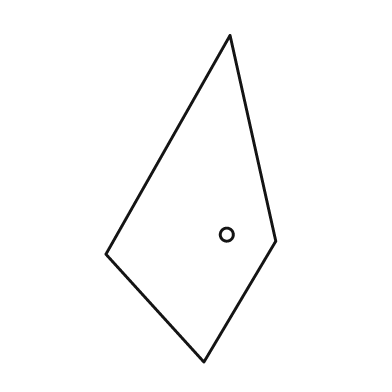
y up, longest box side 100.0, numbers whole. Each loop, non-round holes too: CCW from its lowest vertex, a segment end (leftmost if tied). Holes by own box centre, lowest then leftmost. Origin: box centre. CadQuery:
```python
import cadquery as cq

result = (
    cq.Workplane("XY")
    .moveTo(4.0, -50.0)
    .lineTo(26.0, -13.0)
    .lineTo(12.0, 50.0)
    .lineTo(-26.0, -17.0)
    .close()
    .moveTo(11.0, -11.0)
    .circle(2.0)
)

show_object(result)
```